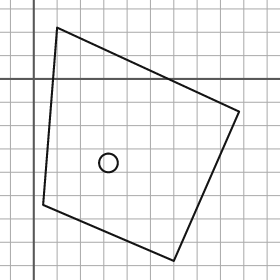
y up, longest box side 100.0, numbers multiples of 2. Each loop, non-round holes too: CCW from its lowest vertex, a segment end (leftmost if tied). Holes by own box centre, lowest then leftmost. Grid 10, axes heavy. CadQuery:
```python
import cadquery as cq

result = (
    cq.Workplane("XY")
    .moveTo(60.0, -78.0)
    .lineTo(88.0, -14.0)
    .lineTo(10.0, 22.0)
    .lineTo(4.0, -54.0)
    .close()
    .moveTo(32.0, -36.0)
    .circle(4.0)
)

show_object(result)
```